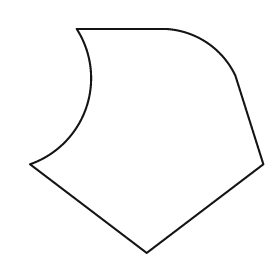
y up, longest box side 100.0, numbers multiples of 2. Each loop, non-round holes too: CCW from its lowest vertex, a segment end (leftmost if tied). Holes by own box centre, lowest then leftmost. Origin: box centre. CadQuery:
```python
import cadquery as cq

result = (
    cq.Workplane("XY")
    .moveTo(0.0, -48.0)
    .lineTo(50.0, -10.0)
    .lineTo(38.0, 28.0)
    .threePointArc((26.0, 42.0), (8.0, 48.0))
    .lineTo(-30.0, 48.0)
    .threePointArc((-26.0, 14.0), (-50.0, -10.0))
    .close()
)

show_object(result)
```